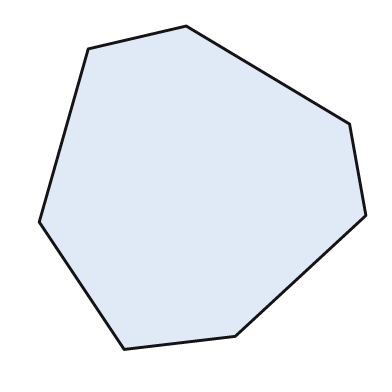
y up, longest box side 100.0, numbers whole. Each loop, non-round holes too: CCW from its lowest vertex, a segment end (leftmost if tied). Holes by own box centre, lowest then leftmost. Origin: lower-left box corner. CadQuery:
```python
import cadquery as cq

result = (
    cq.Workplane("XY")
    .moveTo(26.0, 0.0)
    .lineTo(60.0, 4.0)
    .lineTo(100.0, 41.0)
    .lineTo(95.0, 69.0)
    .lineTo(45.0, 99.0)
    .lineTo(15.0, 92.0)
    .lineTo(0.0, 39.0)
    .close()
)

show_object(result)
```